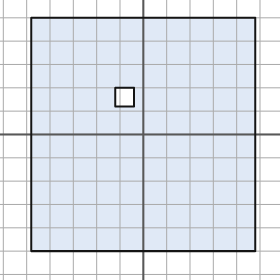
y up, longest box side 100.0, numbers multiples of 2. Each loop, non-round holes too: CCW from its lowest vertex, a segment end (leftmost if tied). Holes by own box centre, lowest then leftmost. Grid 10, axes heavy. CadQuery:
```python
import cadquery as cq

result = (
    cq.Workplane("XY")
    .moveTo(-48.0, -50.0)
    .lineTo(48.0, -50.0)
    .lineTo(48.0, 50.0)
    .lineTo(-48.0, 50.0)
    .close()
    .moveTo(-12.0, 12.0)
    .lineTo(-4.0, 12.0)
    .lineTo(-4.0, 20.0)
    .lineTo(-12.0, 20.0)
    .close()
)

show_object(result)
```